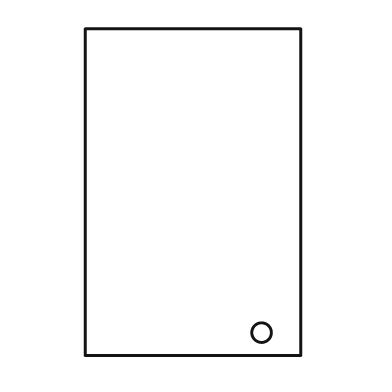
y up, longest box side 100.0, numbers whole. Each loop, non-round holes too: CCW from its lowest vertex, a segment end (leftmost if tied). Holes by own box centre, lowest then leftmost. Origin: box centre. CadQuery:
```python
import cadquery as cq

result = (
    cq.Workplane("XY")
    .moveTo(-33.0, -50.0)
    .lineTo(33.0, -50.0)
    .lineTo(33.0, 50.0)
    .lineTo(-33.0, 50.0)
    .close()
    .moveTo(21.0, -43.0)
    .circle(3.0)
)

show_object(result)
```